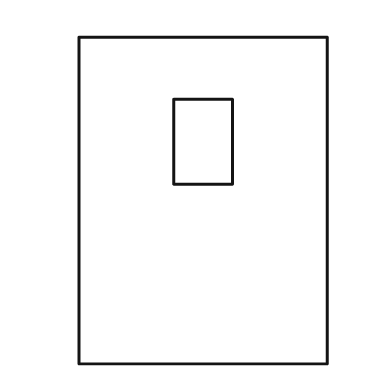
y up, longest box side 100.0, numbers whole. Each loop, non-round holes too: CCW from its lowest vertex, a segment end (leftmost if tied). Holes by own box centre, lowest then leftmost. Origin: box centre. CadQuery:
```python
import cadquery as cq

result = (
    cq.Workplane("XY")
    .moveTo(-38.0, -50.0)
    .lineTo(38.0, -50.0)
    .lineTo(38.0, 50.0)
    .lineTo(-38.0, 50.0)
    .close()
    .moveTo(-9.0, 5.0)
    .lineTo(9.0, 5.0)
    .lineTo(9.0, 31.0)
    .lineTo(-9.0, 31.0)
    .close()
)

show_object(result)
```